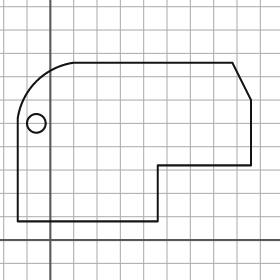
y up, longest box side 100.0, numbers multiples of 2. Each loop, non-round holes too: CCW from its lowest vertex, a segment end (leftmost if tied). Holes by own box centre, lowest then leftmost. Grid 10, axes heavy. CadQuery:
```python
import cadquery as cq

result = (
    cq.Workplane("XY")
    .moveTo(-14.0, 8.0)
    .lineTo(46.0, 8.0)
    .lineTo(46.0, 32.0)
    .lineTo(86.0, 32.0)
    .lineTo(86.0, 60.0)
    .lineTo(78.0, 76.0)
    .lineTo(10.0, 76.0)
    .threePointArc((-6.0, 68.0), (-14.0, 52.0))
    .close()
    .moveTo(-6.0, 50.0)
    .circle(4.0)
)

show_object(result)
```